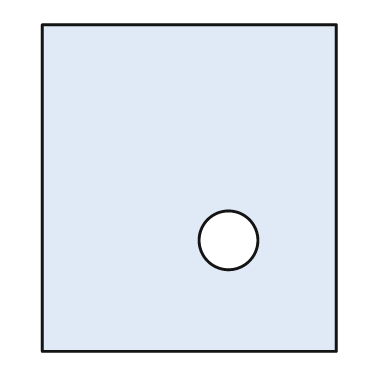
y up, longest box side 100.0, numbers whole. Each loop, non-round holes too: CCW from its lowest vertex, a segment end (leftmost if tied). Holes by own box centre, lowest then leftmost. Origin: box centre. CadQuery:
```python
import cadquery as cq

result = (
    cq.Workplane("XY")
    .moveTo(-45.0, -50.0)
    .lineTo(45.0, -50.0)
    .lineTo(45.0, 50.0)
    .lineTo(-45.0, 50.0)
    .close()
    .moveTo(12.0, -16.0)
    .circle(9.0)
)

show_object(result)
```